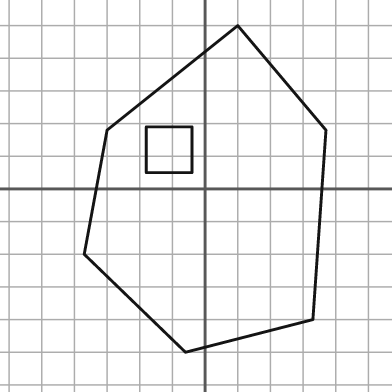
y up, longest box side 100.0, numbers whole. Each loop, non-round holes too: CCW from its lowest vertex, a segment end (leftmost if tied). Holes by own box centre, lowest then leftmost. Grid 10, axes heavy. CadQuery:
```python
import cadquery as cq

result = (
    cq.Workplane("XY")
    .moveTo(-6.0, -50.0)
    .lineTo(33.0, -40.0)
    .lineTo(37.0, 18.0)
    .lineTo(10.0, 50.0)
    .lineTo(-30.0, 18.0)
    .lineTo(-37.0, -20.0)
    .close()
    .moveTo(-18.0, 5.0)
    .lineTo(-4.0, 5.0)
    .lineTo(-4.0, 19.0)
    .lineTo(-18.0, 19.0)
    .close()
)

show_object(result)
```